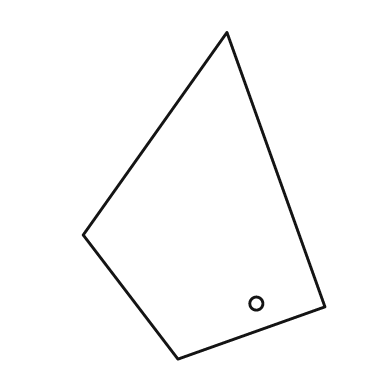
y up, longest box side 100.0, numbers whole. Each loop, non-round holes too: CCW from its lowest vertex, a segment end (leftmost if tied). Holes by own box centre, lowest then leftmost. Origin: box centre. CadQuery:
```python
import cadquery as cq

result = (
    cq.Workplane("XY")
    .moveTo(-8.0, -50.0)
    .lineTo(37.0, -34.0)
    .lineTo(7.0, 50.0)
    .lineTo(-37.0, -12.0)
    .close()
    .moveTo(16.0, -33.0)
    .circle(2.0)
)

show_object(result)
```